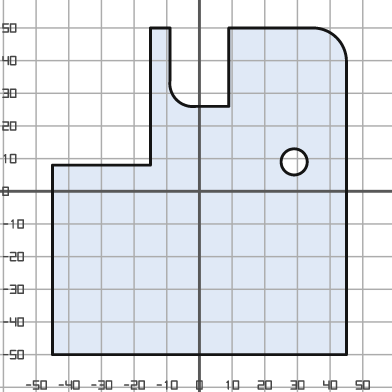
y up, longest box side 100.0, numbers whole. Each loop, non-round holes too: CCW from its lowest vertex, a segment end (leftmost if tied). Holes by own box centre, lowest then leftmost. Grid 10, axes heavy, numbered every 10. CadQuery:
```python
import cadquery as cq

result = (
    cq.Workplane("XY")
    .moveTo(-45.0, -50.0)
    .lineTo(45.0, -50.0)
    .lineTo(45.0, 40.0)
    .threePointArc((42.0, 47.0), (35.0, 50.0))
    .lineTo(9.0, 50.0)
    .lineTo(9.0, 26.0)
    .lineTo(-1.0, 26.0)
    .threePointArc((-7.0, 28.0), (-9.0, 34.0))
    .lineTo(-9.0, 50.0)
    .lineTo(-15.0, 50.0)
    .lineTo(-15.0, 8.0)
    .lineTo(-45.0, 8.0)
    .close()
    .moveTo(29.0, 9.0)
    .circle(4.0)
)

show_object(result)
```